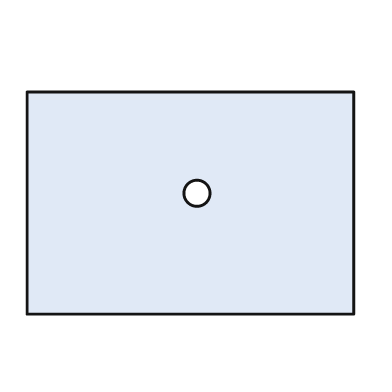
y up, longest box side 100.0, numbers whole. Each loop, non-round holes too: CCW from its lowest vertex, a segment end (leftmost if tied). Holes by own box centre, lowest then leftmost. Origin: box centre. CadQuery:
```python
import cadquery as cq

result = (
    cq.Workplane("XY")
    .moveTo(-50.0, -34.0)
    .lineTo(50.0, -34.0)
    .lineTo(50.0, 34.0)
    .lineTo(-50.0, 34.0)
    .close()
    .moveTo(2.0, 3.0)
    .circle(4.0)
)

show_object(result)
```